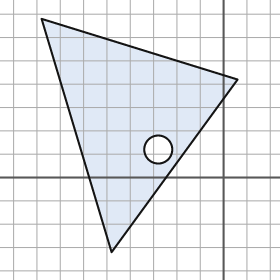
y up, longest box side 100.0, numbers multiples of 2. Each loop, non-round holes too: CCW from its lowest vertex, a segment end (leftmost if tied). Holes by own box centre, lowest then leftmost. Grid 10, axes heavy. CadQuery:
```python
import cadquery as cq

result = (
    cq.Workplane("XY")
    .moveTo(-48.0, -32.0)
    .lineTo(6.0, 42.0)
    .lineTo(-78.0, 68.0)
    .close()
    .moveTo(-28.0, 12.0)
    .circle(6.0)
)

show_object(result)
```